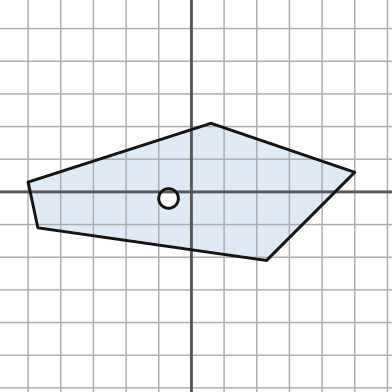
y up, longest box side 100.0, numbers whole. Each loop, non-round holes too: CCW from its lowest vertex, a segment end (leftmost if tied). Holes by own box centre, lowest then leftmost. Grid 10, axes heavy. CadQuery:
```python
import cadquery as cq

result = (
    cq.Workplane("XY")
    .moveTo(23.0, -21.0)
    .lineTo(50.0, 6.0)
    .lineTo(6.0, 21.0)
    .lineTo(-50.0, 3.0)
    .lineTo(-47.0, -11.0)
    .close()
    .moveTo(-7.0, -2.0)
    .circle(3.0)
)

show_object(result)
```